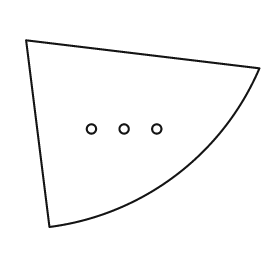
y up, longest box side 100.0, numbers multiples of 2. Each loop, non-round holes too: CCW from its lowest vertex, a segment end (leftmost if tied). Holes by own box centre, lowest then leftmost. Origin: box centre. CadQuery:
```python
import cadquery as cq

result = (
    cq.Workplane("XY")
    .moveTo(-40.0, -40.0)
    .threePointArc((14.0, -18.0), (50.0, 28.0))
    .lineTo(-50.0, 40.0)
    .close()
    .moveTo(-22.0, 2.0)
    .circle(2.0)
    .moveTo(-8.0, 2.0)
    .circle(2.0)
    .moveTo(6.0, 2.0)
    .circle(2.0)
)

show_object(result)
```